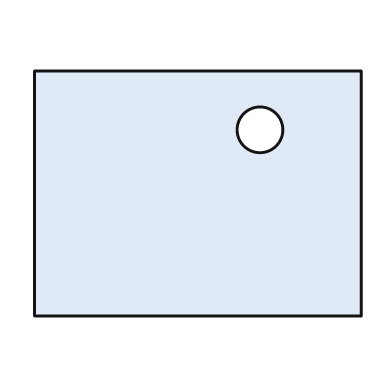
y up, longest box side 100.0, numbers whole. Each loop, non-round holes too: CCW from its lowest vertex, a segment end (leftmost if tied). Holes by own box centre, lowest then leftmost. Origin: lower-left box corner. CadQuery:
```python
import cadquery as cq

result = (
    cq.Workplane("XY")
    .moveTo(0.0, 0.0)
    .lineTo(100.0, 0.0)
    .lineTo(100.0, 75.0)
    .lineTo(0.0, 75.0)
    .close()
    .moveTo(69.0, 57.0)
    .circle(7.0)
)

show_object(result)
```